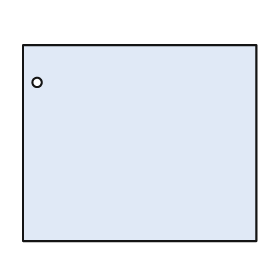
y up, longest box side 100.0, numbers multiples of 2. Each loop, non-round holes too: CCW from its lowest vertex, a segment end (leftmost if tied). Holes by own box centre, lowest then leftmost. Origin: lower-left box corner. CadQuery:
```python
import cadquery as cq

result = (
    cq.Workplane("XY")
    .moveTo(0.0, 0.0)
    .lineTo(100.0, 0.0)
    .lineTo(100.0, 84.0)
    .lineTo(0.0, 84.0)
    .close()
    .moveTo(6.0, 68.0)
    .circle(2.0)
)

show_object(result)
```